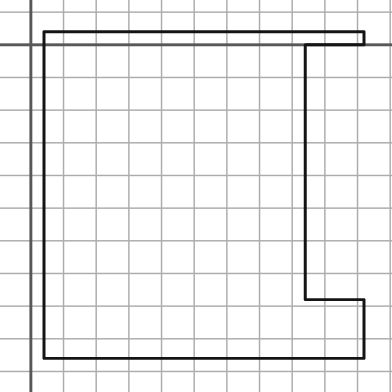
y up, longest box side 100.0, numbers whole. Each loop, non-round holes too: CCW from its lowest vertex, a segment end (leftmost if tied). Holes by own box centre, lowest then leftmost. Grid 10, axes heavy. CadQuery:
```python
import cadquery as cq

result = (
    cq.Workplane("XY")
    .moveTo(4.0, -96.0)
    .lineTo(102.0, -96.0)
    .lineTo(102.0, -78.0)
    .lineTo(84.0, -78.0)
    .lineTo(84.0, 0.0)
    .lineTo(102.0, 0.0)
    .lineTo(102.0, 4.0)
    .lineTo(4.0, 4.0)
    .close()
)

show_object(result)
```